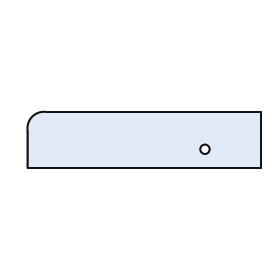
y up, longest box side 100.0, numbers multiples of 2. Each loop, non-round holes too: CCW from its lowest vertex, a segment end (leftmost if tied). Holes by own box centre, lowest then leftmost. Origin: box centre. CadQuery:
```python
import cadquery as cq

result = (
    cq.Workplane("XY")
    .moveTo(-50.0, -12.0)
    .lineTo(50.0, -12.0)
    .lineTo(50.0, 12.0)
    .lineTo(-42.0, 12.0)
    .threePointArc((-48.0, 10.0), (-50.0, 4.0))
    .close()
    .moveTo(26.0, -4.0)
    .circle(2.0)
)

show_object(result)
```